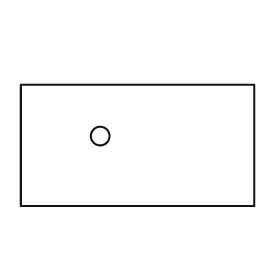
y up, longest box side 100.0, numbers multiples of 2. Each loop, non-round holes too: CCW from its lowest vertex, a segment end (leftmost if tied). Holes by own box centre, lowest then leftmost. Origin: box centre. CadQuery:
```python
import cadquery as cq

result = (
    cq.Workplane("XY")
    .moveTo(-50.0, -26.0)
    .lineTo(50.0, -26.0)
    .lineTo(50.0, 26.0)
    .lineTo(-50.0, 26.0)
    .close()
    .moveTo(-16.0, 4.0)
    .circle(4.0)
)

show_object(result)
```